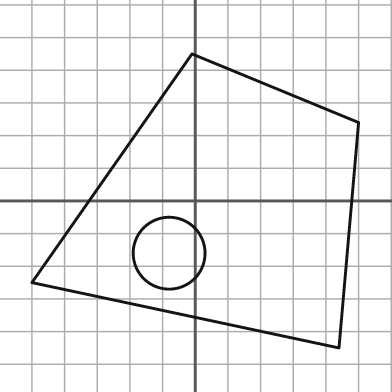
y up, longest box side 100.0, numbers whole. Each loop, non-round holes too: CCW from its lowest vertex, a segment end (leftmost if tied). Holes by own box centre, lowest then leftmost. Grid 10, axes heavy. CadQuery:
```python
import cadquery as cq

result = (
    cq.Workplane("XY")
    .moveTo(44.0, -45.0)
    .lineTo(50.0, 24.0)
    .lineTo(-1.0, 45.0)
    .lineTo(-50.0, -25.0)
    .close()
    .moveTo(-8.0, -16.0)
    .circle(11.0)
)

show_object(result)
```